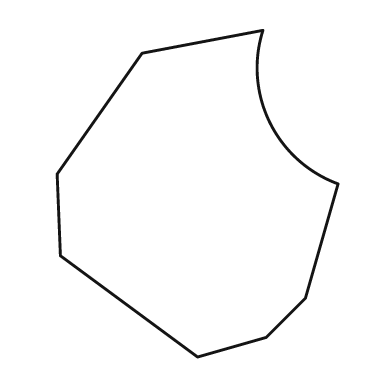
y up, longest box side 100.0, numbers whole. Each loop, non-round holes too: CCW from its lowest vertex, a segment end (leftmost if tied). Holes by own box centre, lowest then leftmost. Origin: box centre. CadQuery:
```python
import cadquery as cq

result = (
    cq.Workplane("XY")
    .moveTo(0.0, -50.0)
    .lineTo(21.0, -44.0)
    .lineTo(33.0, -32.0)
    .lineTo(43.0, 3.0)
    .threePointArc((22.0, 22.0), (20.0, 50.0))
    .lineTo(-17.0, 43.0)
    .lineTo(-43.0, 6.0)
    .lineTo(-42.0, -19.0)
    .close()
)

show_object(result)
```